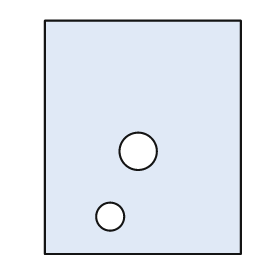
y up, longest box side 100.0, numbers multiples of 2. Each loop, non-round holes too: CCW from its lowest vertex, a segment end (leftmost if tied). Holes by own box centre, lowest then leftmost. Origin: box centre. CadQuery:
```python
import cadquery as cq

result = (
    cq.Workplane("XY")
    .moveTo(-42.0, -50.0)
    .lineTo(42.0, -50.0)
    .lineTo(42.0, 50.0)
    .lineTo(-42.0, 50.0)
    .close()
    .moveTo(-14.0, -34.0)
    .circle(6.0)
    .moveTo(-2.0, -6.0)
    .circle(8.0)
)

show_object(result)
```